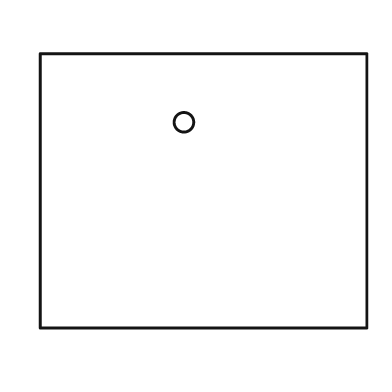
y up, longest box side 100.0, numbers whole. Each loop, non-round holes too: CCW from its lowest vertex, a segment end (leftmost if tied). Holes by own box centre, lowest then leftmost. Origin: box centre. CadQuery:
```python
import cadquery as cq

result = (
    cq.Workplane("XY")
    .moveTo(-50.0, -42.0)
    .lineTo(50.0, -42.0)
    .lineTo(50.0, 42.0)
    .lineTo(-50.0, 42.0)
    .close()
    .moveTo(-6.0, 21.0)
    .circle(3.0)
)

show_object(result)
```